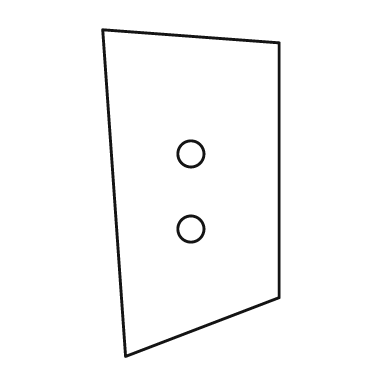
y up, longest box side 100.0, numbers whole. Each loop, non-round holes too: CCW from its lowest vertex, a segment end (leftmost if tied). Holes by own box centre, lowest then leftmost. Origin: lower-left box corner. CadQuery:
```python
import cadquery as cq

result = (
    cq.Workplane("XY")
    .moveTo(7.0, 0.0)
    .lineTo(54.0, 18.0)
    .lineTo(54.0, 96.0)
    .lineTo(0.0, 100.0)
    .close()
    .moveTo(27.0, 39.0)
    .circle(4.0)
    .moveTo(27.0, 62.0)
    .circle(4.0)
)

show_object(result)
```